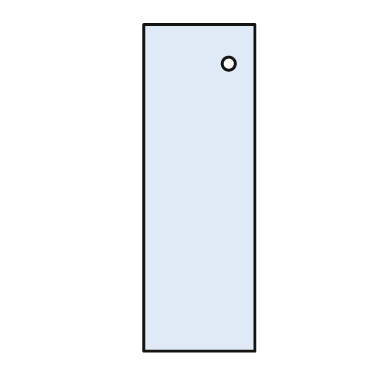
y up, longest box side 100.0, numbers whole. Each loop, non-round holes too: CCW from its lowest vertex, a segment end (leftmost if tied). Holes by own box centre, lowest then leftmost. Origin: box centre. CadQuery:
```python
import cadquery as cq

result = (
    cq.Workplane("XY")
    .moveTo(-17.0, -50.0)
    .lineTo(17.0, -50.0)
    .lineTo(17.0, 50.0)
    .lineTo(-17.0, 50.0)
    .close()
    .moveTo(9.0, 38.0)
    .circle(2.0)
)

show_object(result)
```